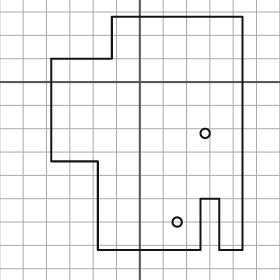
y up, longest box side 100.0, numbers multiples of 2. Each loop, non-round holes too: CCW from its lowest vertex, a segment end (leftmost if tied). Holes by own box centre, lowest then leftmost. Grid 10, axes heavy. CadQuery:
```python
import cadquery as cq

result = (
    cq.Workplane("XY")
    .moveTo(-18.0, -72.0)
    .lineTo(26.0, -72.0)
    .lineTo(26.0, -50.0)
    .lineTo(34.0, -50.0)
    .lineTo(34.0, -72.0)
    .lineTo(44.0, -72.0)
    .lineTo(44.0, 28.0)
    .lineTo(-12.0, 28.0)
    .lineTo(-12.0, 10.0)
    .lineTo(-38.0, 10.0)
    .lineTo(-38.0, -34.0)
    .lineTo(-18.0, -34.0)
    .close()
    .moveTo(16.0, -60.0)
    .circle(2.0)
    .moveTo(28.0, -22.0)
    .circle(2.0)
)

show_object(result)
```